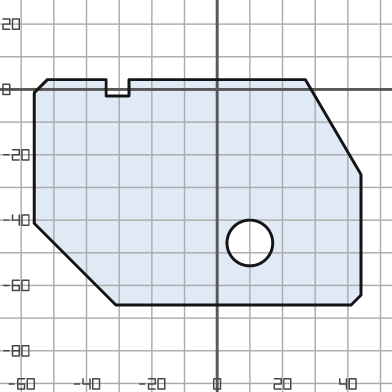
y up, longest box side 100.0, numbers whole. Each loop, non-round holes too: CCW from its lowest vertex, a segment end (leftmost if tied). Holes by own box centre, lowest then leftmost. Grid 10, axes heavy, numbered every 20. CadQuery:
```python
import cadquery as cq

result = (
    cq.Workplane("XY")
    .moveTo(-31.0, -66.0)
    .lineTo(41.0, -66.0)
    .lineTo(44.0, -63.0)
    .lineTo(44.0, -26.0)
    .lineTo(27.0, 3.0)
    .lineTo(-27.0, 3.0)
    .lineTo(-27.0, -2.0)
    .lineTo(-34.0, -2.0)
    .lineTo(-34.0, 3.0)
    .lineTo(-52.0, 3.0)
    .lineTo(-56.0, -1.0)
    .lineTo(-56.0, -41.0)
    .close()
    .moveTo(10.0, -47.0)
    .circle(7.0)
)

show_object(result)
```